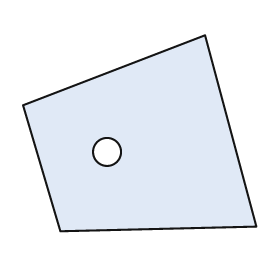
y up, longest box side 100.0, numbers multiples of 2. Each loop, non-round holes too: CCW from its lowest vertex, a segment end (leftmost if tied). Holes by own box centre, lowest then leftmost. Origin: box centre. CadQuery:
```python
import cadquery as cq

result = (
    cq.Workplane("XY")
    .moveTo(-34.0, -42.0)
    .lineTo(50.0, -40.0)
    .lineTo(28.0, 42.0)
    .lineTo(-50.0, 12.0)
    .close()
    .moveTo(-14.0, -8.0)
    .circle(6.0)
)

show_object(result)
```